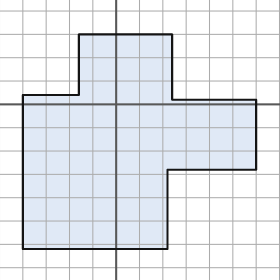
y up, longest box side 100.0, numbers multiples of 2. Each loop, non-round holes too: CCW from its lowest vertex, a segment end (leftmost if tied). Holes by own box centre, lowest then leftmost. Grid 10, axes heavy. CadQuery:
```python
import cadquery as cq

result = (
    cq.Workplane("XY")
    .moveTo(-40.0, -62.0)
    .lineTo(22.0, -62.0)
    .lineTo(22.0, -28.0)
    .lineTo(60.0, -28.0)
    .lineTo(60.0, 2.0)
    .lineTo(24.0, 2.0)
    .lineTo(24.0, 30.0)
    .lineTo(-16.0, 30.0)
    .lineTo(-16.0, 4.0)
    .lineTo(-40.0, 4.0)
    .close()
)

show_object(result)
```